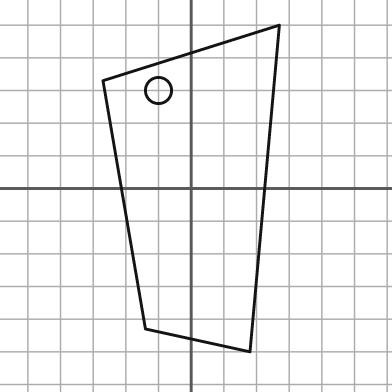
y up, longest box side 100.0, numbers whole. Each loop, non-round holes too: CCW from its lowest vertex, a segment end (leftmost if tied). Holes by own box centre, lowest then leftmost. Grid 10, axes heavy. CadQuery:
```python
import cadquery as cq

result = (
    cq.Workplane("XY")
    .moveTo(18.0, -50.0)
    .lineTo(27.0, 50.0)
    .lineTo(-27.0, 33.0)
    .lineTo(-14.0, -43.0)
    .close()
    .moveTo(-10.0, 30.0)
    .circle(4.0)
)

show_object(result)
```